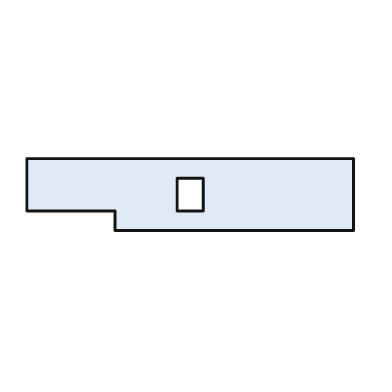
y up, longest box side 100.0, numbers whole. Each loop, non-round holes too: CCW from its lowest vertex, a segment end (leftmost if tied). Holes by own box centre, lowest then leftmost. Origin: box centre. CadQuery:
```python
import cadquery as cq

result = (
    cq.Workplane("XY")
    .moveTo(-23.0, -11.0)
    .lineTo(50.0, -11.0)
    .lineTo(50.0, 11.0)
    .lineTo(-50.0, 11.0)
    .lineTo(-50.0, -5.0)
    .lineTo(-23.0, -5.0)
    .close()
    .moveTo(-4.0, -5.0)
    .lineTo(4.0, -5.0)
    .lineTo(4.0, 5.0)
    .lineTo(-4.0, 5.0)
    .close()
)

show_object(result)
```